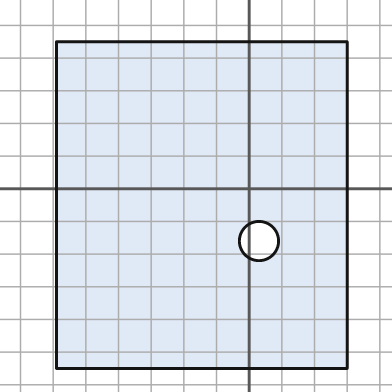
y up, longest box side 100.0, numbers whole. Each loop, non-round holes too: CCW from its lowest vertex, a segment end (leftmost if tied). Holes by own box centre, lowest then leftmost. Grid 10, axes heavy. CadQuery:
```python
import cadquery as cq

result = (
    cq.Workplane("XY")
    .moveTo(-59.0, -55.0)
    .lineTo(30.0, -55.0)
    .lineTo(30.0, 45.0)
    .lineTo(-59.0, 45.0)
    .close()
    .moveTo(3.0, -16.0)
    .circle(6.0)
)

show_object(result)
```